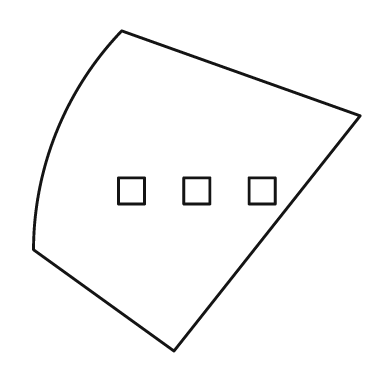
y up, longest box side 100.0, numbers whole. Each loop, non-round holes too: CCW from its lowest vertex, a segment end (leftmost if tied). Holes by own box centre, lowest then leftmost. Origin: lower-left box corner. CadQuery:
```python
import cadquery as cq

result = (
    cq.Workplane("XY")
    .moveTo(43.0, 0.0)
    .lineTo(100.0, 72.0)
    .lineTo(27.0, 98.0)
    .threePointArc((7.0, 67.0), (0.0, 31.0))
    .close()
    .moveTo(26.0, 45.0)
    .lineTo(34.0, 45.0)
    .lineTo(34.0, 53.0)
    .lineTo(26.0, 53.0)
    .close()
    .moveTo(46.0, 45.0)
    .lineTo(54.0, 45.0)
    .lineTo(54.0, 53.0)
    .lineTo(46.0, 53.0)
    .close()
    .moveTo(66.0, 45.0)
    .lineTo(74.0, 45.0)
    .lineTo(74.0, 53.0)
    .lineTo(66.0, 53.0)
    .close()
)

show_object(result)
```